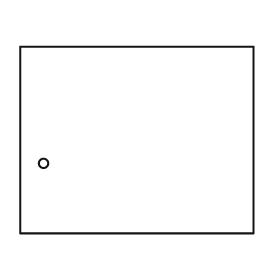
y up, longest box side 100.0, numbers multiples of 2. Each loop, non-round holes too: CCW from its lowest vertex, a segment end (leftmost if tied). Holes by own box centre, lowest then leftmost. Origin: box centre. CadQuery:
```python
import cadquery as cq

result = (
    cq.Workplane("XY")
    .moveTo(-50.0, -40.0)
    .lineTo(50.0, -40.0)
    .lineTo(50.0, 40.0)
    .lineTo(-50.0, 40.0)
    .close()
    .moveTo(-40.0, -10.0)
    .circle(2.0)
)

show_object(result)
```